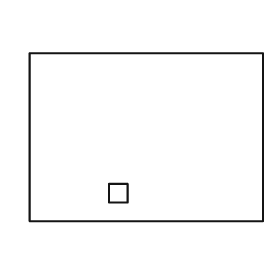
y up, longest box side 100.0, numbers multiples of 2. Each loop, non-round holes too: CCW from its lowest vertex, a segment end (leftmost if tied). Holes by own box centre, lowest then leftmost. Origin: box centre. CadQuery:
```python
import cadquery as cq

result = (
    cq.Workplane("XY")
    .moveTo(-50.0, -36.0)
    .lineTo(50.0, -36.0)
    .lineTo(50.0, 36.0)
    .lineTo(-50.0, 36.0)
    .close()
    .moveTo(-16.0, -28.0)
    .lineTo(-8.0, -28.0)
    .lineTo(-8.0, -20.0)
    .lineTo(-16.0, -20.0)
    .close()
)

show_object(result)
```